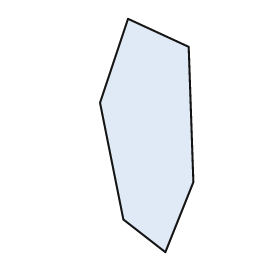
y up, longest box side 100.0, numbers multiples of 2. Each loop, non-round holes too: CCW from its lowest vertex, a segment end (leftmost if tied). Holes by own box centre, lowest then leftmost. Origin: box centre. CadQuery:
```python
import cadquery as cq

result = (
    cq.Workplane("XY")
    .moveTo(8.0, -50.0)
    .lineTo(20.0, -20.0)
    .lineTo(18.0, 38.0)
    .lineTo(-8.0, 50.0)
    .lineTo(-20.0, 14.0)
    .lineTo(-10.0, -36.0)
    .close()
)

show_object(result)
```